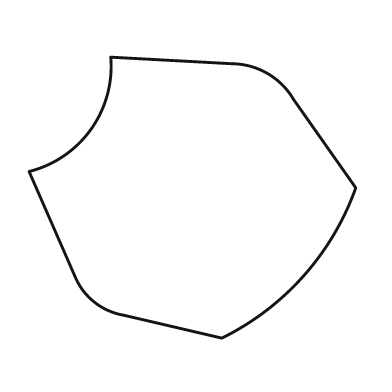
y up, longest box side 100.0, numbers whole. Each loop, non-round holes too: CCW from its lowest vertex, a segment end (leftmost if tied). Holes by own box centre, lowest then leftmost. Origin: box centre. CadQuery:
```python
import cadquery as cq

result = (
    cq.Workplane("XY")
    .moveTo(9.0, -43.0)
    .threePointArc((34.0, -24.0), (50.0, 3.0))
    .lineTo(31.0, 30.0)
    .threePointArc((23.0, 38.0), (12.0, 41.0))
    .lineTo(-25.0, 43.0)
    .threePointArc((-31.0, 21.0), (-50.0, 8.0))
    .lineTo(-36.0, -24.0)
    .threePointArc((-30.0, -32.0), (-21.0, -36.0))
    .close()
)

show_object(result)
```